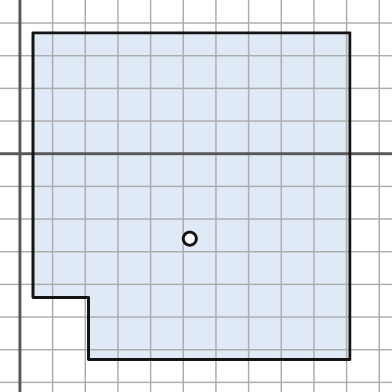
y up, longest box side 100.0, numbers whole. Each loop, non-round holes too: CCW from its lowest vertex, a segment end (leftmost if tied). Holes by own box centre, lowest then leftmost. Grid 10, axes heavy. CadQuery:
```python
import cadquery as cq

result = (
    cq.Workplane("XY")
    .moveTo(21.0, -63.0)
    .lineTo(101.0, -63.0)
    .lineTo(101.0, 37.0)
    .lineTo(4.0, 37.0)
    .lineTo(4.0, -44.0)
    .lineTo(21.0, -44.0)
    .close()
    .moveTo(52.0, -26.0)
    .circle(2.0)
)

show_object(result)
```